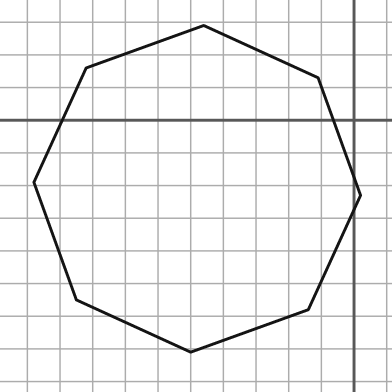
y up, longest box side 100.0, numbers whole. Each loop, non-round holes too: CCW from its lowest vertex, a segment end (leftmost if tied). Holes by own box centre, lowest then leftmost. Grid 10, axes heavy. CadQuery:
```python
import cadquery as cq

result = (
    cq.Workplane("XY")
    .moveTo(-50.0, -71.0)
    .lineTo(-14.0, -58.0)
    .lineTo(2.0, -23.0)
    .lineTo(-11.0, 13.0)
    .lineTo(-46.0, 29.0)
    .lineTo(-82.0, 16.0)
    .lineTo(-98.0, -19.0)
    .lineTo(-85.0, -55.0)
    .close()
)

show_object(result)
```